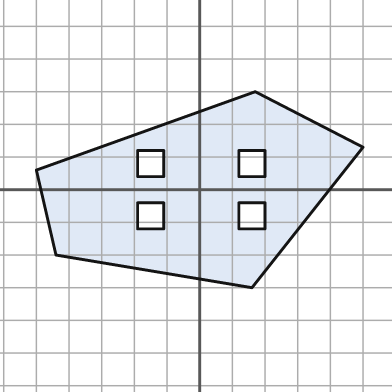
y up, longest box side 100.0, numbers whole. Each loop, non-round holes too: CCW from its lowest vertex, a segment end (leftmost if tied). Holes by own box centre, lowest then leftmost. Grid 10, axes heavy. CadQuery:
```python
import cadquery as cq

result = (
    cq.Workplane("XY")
    .moveTo(16.0, -30.0)
    .lineTo(50.0, 13.0)
    .lineTo(17.0, 30.0)
    .lineTo(-50.0, 6.0)
    .lineTo(-44.0, -20.0)
    .close()
    .moveTo(-19.0, -12.0)
    .lineTo(-11.0, -12.0)
    .lineTo(-11.0, -4.0)
    .lineTo(-19.0, -4.0)
    .close()
    .moveTo(12.0, -12.0)
    .lineTo(20.0, -12.0)
    .lineTo(20.0, -4.0)
    .lineTo(12.0, -4.0)
    .close()
    .moveTo(-19.0, 4.0)
    .lineTo(-11.0, 4.0)
    .lineTo(-11.0, 12.0)
    .lineTo(-19.0, 12.0)
    .close()
    .moveTo(12.0, 4.0)
    .lineTo(20.0, 4.0)
    .lineTo(20.0, 12.0)
    .lineTo(12.0, 12.0)
    .close()
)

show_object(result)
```